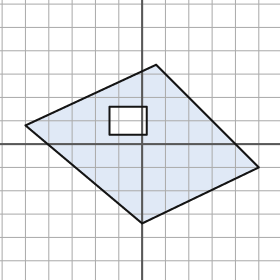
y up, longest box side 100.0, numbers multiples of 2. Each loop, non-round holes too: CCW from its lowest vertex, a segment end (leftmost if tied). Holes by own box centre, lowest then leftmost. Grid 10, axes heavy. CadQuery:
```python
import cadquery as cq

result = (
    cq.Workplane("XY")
    .moveTo(0.0, -34.0)
    .lineTo(50.0, -10.0)
    .lineTo(6.0, 34.0)
    .lineTo(-50.0, 8.0)
    .close()
    .moveTo(-14.0, 4.0)
    .lineTo(2.0, 4.0)
    .lineTo(2.0, 16.0)
    .lineTo(-14.0, 16.0)
    .close()
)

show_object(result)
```